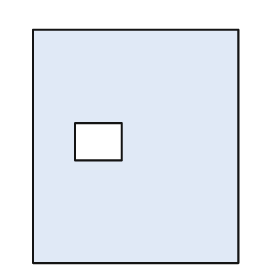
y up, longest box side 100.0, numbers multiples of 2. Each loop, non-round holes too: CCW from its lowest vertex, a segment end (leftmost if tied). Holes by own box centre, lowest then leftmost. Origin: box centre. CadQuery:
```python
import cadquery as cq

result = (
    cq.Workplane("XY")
    .moveTo(-44.0, -50.0)
    .lineTo(44.0, -50.0)
    .lineTo(44.0, 50.0)
    .lineTo(-44.0, 50.0)
    .close()
    .moveTo(-26.0, -6.0)
    .lineTo(-6.0, -6.0)
    .lineTo(-6.0, 10.0)
    .lineTo(-26.0, 10.0)
    .close()
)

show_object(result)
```